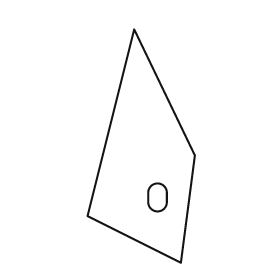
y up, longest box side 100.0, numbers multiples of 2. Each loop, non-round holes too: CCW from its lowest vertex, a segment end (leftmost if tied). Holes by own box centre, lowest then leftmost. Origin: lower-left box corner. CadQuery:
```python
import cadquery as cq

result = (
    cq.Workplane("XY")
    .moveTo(40.0, 0.0)
    .lineTo(46.0, 46.0)
    .lineTo(20.0, 100.0)
    .lineTo(0.0, 20.0)
    .close()
    .moveTo(26.0, 26.0)
    .threePointArc((30.0, 22.0), (34.0, 26.0))
    .lineTo(34.0, 30.0)
    .threePointArc((30.0, 34.0), (26.0, 30.0))
    .close()
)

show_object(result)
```